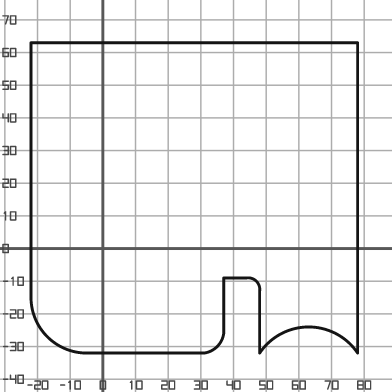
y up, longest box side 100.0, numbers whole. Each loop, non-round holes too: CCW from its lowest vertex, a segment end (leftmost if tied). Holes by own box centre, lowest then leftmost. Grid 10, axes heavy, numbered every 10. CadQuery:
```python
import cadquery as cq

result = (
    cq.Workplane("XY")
    .moveTo(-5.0, -32.0)
    .lineTo(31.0, -32.0)
    .threePointArc((35.0, -30.0), (37.0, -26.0))
    .lineTo(37.0, -9.0)
    .lineTo(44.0, -9.0)
    .threePointArc((47.0, -10.0), (48.0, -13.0))
    .lineTo(48.0, -32.0)
    .threePointArc((63.0, -24.0), (78.0, -32.0))
    .lineTo(78.0, 63.0)
    .lineTo(-22.0, 63.0)
    .lineTo(-22.0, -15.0)
    .threePointArc((-17.0, -27.0), (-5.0, -32.0))
    .close()
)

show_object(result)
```